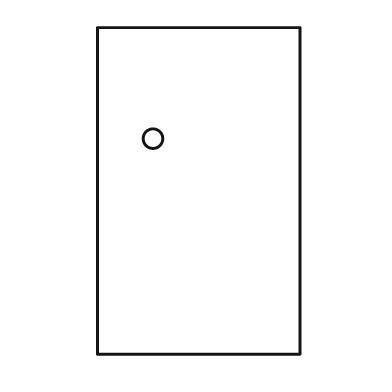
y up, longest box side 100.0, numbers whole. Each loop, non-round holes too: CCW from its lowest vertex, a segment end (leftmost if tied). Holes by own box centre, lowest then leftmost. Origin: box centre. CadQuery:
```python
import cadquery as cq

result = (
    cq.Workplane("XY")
    .moveTo(-31.0, -50.0)
    .lineTo(31.0, -50.0)
    .lineTo(31.0, 50.0)
    .lineTo(-31.0, 50.0)
    .close()
    .moveTo(-14.0, 16.0)
    .circle(3.0)
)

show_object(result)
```